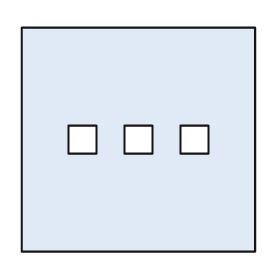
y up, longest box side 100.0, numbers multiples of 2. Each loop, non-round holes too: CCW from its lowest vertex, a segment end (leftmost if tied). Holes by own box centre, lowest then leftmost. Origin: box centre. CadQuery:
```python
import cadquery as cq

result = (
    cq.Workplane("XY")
    .moveTo(-50.0, -48.0)
    .lineTo(50.0, -48.0)
    .lineTo(50.0, 48.0)
    .lineTo(-50.0, 48.0)
    .close()
    .moveTo(-30.0, -6.0)
    .lineTo(-18.0, -6.0)
    .lineTo(-18.0, 6.0)
    .lineTo(-30.0, 6.0)
    .close()
    .moveTo(-6.0, -6.0)
    .lineTo(6.0, -6.0)
    .lineTo(6.0, 6.0)
    .lineTo(-6.0, 6.0)
    .close()
    .moveTo(18.0, -6.0)
    .lineTo(30.0, -6.0)
    .lineTo(30.0, 6.0)
    .lineTo(18.0, 6.0)
    .close()
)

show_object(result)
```